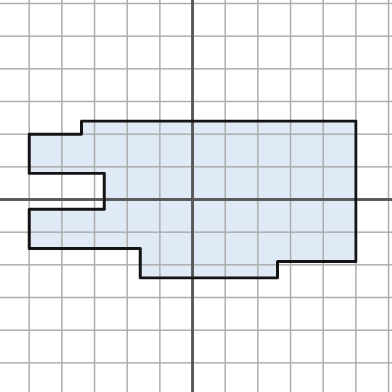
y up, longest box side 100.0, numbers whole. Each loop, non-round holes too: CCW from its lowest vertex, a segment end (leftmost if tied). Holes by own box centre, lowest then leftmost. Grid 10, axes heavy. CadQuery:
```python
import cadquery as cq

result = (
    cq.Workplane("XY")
    .moveTo(-16.0, -24.0)
    .lineTo(26.0, -24.0)
    .lineTo(26.0, -19.0)
    .lineTo(50.0, -19.0)
    .lineTo(50.0, 24.0)
    .lineTo(-34.0, 24.0)
    .lineTo(-34.0, 20.0)
    .lineTo(-50.0, 20.0)
    .lineTo(-50.0, 8.0)
    .lineTo(-27.0, 8.0)
    .lineTo(-27.0, -3.0)
    .lineTo(-50.0, -3.0)
    .lineTo(-50.0, -15.0)
    .lineTo(-16.0, -15.0)
    .close()
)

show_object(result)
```